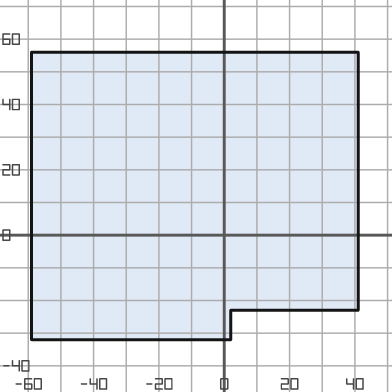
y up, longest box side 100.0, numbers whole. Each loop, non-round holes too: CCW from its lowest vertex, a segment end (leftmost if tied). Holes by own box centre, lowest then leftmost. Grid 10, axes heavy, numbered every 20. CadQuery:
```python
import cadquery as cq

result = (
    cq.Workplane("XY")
    .moveTo(-59.0, -32.0)
    .lineTo(2.0, -32.0)
    .lineTo(2.0, -23.0)
    .lineTo(41.0, -23.0)
    .lineTo(41.0, 56.0)
    .lineTo(-59.0, 56.0)
    .close()
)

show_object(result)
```